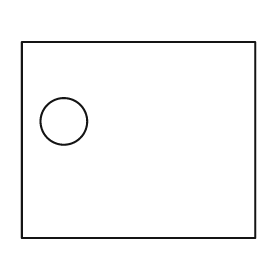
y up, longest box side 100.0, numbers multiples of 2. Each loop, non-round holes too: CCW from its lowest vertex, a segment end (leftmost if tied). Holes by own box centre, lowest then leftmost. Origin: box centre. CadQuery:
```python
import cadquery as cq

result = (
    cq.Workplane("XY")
    .moveTo(-50.0, -42.0)
    .lineTo(50.0, -42.0)
    .lineTo(50.0, 42.0)
    .lineTo(-50.0, 42.0)
    .close()
    .moveTo(-32.0, 8.0)
    .circle(10.0)
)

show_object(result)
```